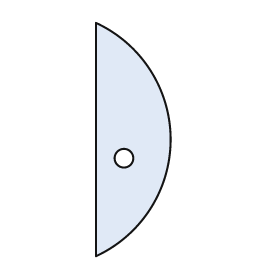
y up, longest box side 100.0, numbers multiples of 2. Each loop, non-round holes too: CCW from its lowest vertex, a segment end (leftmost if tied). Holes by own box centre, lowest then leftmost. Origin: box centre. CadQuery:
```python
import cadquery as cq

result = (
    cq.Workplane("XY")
    .moveTo(-16.0, -50.0)
    .threePointArc((16.0, 0.0), (-16.0, 50.0))
    .close()
    .moveTo(-4.0, -8.0)
    .circle(4.0)
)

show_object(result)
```